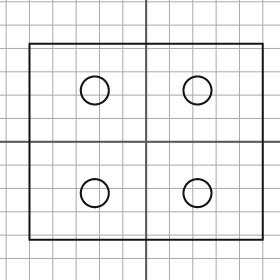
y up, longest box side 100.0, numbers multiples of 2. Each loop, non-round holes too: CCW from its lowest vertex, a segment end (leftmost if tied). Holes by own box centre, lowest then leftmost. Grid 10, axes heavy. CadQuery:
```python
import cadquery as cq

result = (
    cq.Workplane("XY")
    .moveTo(-50.0, -42.0)
    .lineTo(50.0, -42.0)
    .lineTo(50.0, 42.0)
    .lineTo(-50.0, 42.0)
    .close()
    .moveTo(-22.0, -22.0)
    .circle(6.0)
    .moveTo(22.0, -22.0)
    .circle(6.0)
    .moveTo(-22.0, 22.0)
    .circle(6.0)
    .moveTo(22.0, 22.0)
    .circle(6.0)
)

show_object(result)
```